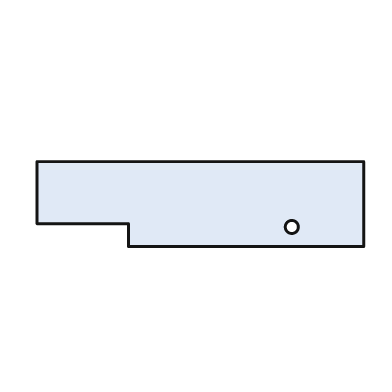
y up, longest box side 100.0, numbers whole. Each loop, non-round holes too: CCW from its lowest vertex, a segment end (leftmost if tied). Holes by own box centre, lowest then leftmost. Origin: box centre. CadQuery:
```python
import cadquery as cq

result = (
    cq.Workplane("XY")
    .moveTo(-22.0, -13.0)
    .lineTo(50.0, -13.0)
    .lineTo(50.0, 13.0)
    .lineTo(-50.0, 13.0)
    .lineTo(-50.0, -6.0)
    .lineTo(-22.0, -6.0)
    .close()
    .moveTo(28.0, -7.0)
    .circle(2.0)
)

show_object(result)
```